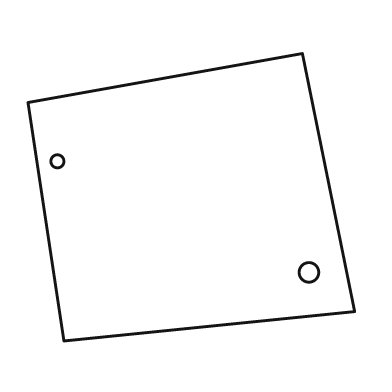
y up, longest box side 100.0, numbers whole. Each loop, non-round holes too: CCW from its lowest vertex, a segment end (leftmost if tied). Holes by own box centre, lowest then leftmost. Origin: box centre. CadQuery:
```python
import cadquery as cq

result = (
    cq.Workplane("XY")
    .moveTo(-39.0, -44.0)
    .lineTo(50.0, -35.0)
    .lineTo(34.0, 44.0)
    .lineTo(-50.0, 29.0)
    .close()
    .moveTo(36.0, -23.0)
    .circle(3.0)
    .moveTo(-41.0, 11.0)
    .circle(2.0)
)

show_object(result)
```